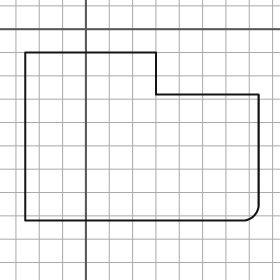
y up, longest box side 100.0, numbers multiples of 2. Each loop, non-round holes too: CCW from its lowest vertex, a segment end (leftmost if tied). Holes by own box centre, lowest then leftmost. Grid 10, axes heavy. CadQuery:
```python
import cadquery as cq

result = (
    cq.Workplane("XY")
    .moveTo(-26.0, -82.0)
    .lineTo(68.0, -82.0)
    .threePointArc((72.0, -80.0), (74.0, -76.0))
    .lineTo(74.0, -28.0)
    .lineTo(30.0, -28.0)
    .lineTo(30.0, -10.0)
    .lineTo(-26.0, -10.0)
    .close()
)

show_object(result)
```